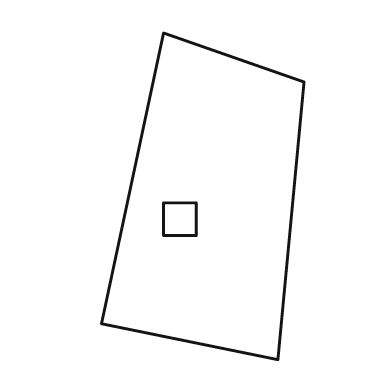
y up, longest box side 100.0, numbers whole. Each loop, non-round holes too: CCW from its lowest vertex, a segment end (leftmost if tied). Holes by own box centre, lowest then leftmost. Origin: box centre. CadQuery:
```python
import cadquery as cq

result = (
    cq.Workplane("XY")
    .moveTo(23.0, -50.0)
    .lineTo(31.0, 35.0)
    .lineTo(-12.0, 50.0)
    .lineTo(-31.0, -39.0)
    .close()
    .moveTo(-12.0, -12.0)
    .lineTo(-2.0, -12.0)
    .lineTo(-2.0, -2.0)
    .lineTo(-12.0, -2.0)
    .close()
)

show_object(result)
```